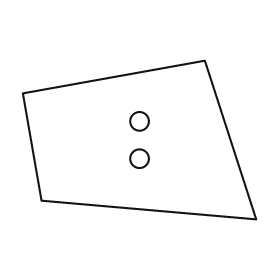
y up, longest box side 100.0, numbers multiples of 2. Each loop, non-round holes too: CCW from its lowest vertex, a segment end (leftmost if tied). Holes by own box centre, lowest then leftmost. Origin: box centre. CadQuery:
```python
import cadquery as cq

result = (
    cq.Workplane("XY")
    .moveTo(50.0, -34.0)
    .lineTo(28.0, 34.0)
    .lineTo(-50.0, 20.0)
    .lineTo(-42.0, -26.0)
    .close()
    .moveTo(0.0, -8.0)
    .circle(4.0)
    .moveTo(0.0, 8.0)
    .circle(4.0)
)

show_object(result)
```